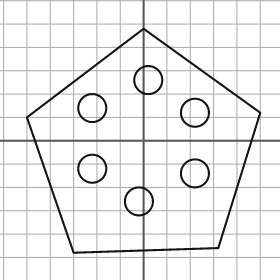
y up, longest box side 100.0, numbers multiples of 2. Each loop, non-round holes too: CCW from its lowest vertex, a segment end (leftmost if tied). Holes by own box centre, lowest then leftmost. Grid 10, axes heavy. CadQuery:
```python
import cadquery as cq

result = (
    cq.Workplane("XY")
    .moveTo(-30.0, -48.0)
    .lineTo(32.0, -46.0)
    .lineTo(50.0, 12.0)
    .lineTo(0.0, 48.0)
    .lineTo(-50.0, 10.0)
    .close()
    .moveTo(-2.0, -26.0)
    .circle(6.0)
    .moveTo(22.0, -14.0)
    .circle(6.0)
    .moveTo(-22.0, -12.0)
    .circle(6.0)
    .moveTo(22.0, 12.0)
    .circle(6.0)
    .moveTo(-22.0, 14.0)
    .circle(6.0)
    .moveTo(2.0, 26.0)
    .circle(6.0)
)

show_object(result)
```